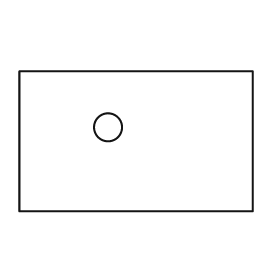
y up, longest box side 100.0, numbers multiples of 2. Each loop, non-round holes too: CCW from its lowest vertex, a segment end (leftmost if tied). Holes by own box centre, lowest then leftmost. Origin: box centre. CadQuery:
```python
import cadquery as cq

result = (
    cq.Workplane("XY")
    .moveTo(-50.0, -30.0)
    .lineTo(50.0, -30.0)
    .lineTo(50.0, 30.0)
    .lineTo(-50.0, 30.0)
    .close()
    .moveTo(-12.0, 6.0)
    .circle(6.0)
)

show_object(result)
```